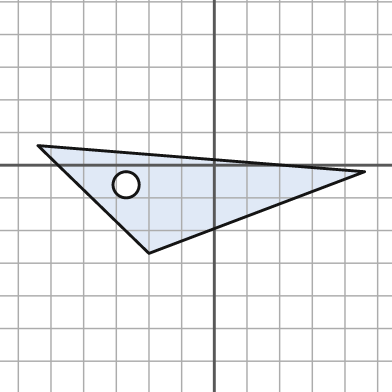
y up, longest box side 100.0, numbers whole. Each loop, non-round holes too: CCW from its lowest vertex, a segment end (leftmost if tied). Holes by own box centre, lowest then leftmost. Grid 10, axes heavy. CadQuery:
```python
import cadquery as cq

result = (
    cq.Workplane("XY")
    .moveTo(-20.0, -27.0)
    .lineTo(46.0, -2.0)
    .lineTo(-54.0, 6.0)
    .close()
    .moveTo(-27.0, -6.0)
    .circle(4.0)
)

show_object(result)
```